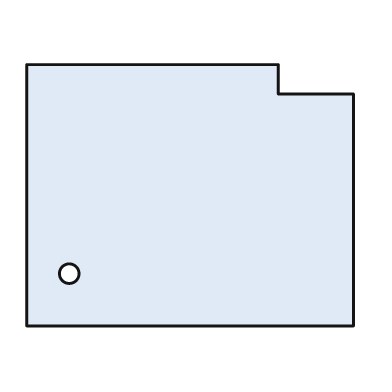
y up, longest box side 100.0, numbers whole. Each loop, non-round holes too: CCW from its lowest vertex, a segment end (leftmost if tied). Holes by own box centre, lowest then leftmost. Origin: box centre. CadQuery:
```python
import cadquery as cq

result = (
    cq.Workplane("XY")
    .moveTo(-50.0, -40.0)
    .lineTo(50.0, -40.0)
    .lineTo(50.0, 31.0)
    .lineTo(27.0, 31.0)
    .lineTo(27.0, 40.0)
    .lineTo(-50.0, 40.0)
    .close()
    .moveTo(-37.0, -24.0)
    .circle(3.0)
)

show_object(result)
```